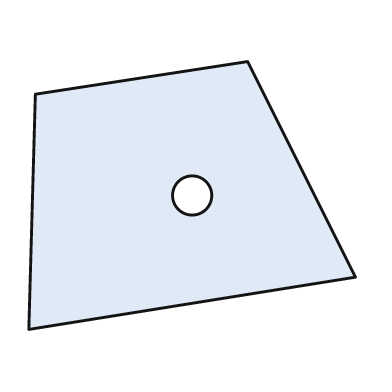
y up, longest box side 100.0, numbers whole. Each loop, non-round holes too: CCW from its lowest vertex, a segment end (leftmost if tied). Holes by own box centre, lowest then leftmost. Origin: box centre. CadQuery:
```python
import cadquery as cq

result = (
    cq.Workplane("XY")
    .moveTo(-50.0, -41.0)
    .lineTo(50.0, -25.0)
    .lineTo(17.0, 41.0)
    .lineTo(-48.0, 31.0)
    .close()
    .moveTo(0.0, 0.0)
    .circle(6.0)
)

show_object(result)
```